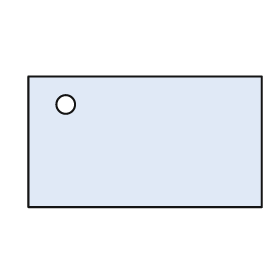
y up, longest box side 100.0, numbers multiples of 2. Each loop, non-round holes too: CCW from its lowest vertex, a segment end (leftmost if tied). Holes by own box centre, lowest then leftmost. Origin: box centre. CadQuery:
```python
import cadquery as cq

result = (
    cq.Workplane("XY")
    .moveTo(-50.0, -28.0)
    .lineTo(50.0, -28.0)
    .lineTo(50.0, 28.0)
    .lineTo(-50.0, 28.0)
    .close()
    .moveTo(-34.0, 16.0)
    .circle(4.0)
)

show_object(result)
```